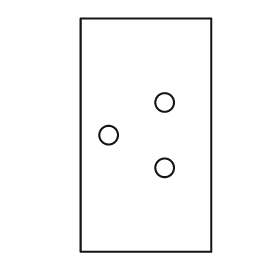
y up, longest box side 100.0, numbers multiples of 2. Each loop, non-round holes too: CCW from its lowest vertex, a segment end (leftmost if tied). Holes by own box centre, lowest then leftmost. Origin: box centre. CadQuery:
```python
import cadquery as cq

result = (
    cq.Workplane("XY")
    .moveTo(-28.0, -50.0)
    .lineTo(28.0, -50.0)
    .lineTo(28.0, 50.0)
    .lineTo(-28.0, 50.0)
    .close()
    .moveTo(8.0, -14.0)
    .circle(4.0)
    .moveTo(-16.0, 0.0)
    .circle(4.0)
    .moveTo(8.0, 14.0)
    .circle(4.0)
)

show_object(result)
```